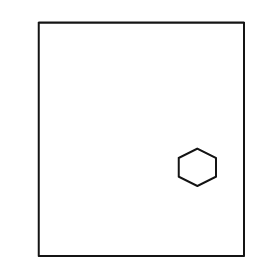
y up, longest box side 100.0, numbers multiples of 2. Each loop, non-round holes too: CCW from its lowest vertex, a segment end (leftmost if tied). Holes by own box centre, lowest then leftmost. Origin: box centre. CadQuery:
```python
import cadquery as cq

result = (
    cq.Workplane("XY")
    .moveTo(-44.0, -50.0)
    .lineTo(44.0, -50.0)
    .lineTo(44.0, 50.0)
    .lineTo(-44.0, 50.0)
    .close()
    .moveTo(24.0, -20.0)
    .lineTo(32.0, -16.0)
    .lineTo(32.0, -8.0)
    .lineTo(24.0, -4.0)
    .lineTo(16.0, -8.0)
    .lineTo(16.0, -16.0)
    .close()
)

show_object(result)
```